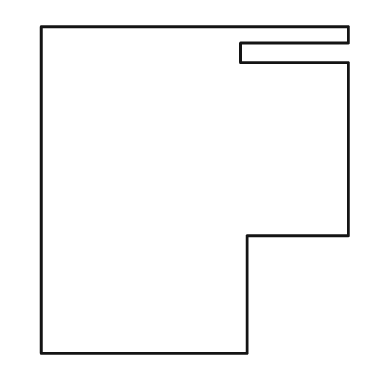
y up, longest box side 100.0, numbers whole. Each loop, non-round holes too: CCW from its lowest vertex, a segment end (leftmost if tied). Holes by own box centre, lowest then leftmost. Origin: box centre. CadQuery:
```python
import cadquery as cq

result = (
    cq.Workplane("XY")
    .moveTo(-47.0, -50.0)
    .lineTo(16.0, -50.0)
    .lineTo(16.0, -14.0)
    .lineTo(47.0, -14.0)
    .lineTo(47.0, 39.0)
    .lineTo(14.0, 39.0)
    .lineTo(14.0, 45.0)
    .lineTo(47.0, 45.0)
    .lineTo(47.0, 50.0)
    .lineTo(-47.0, 50.0)
    .close()
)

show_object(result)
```